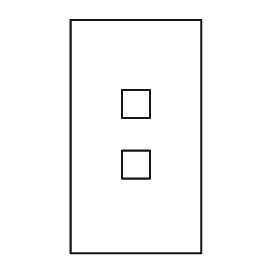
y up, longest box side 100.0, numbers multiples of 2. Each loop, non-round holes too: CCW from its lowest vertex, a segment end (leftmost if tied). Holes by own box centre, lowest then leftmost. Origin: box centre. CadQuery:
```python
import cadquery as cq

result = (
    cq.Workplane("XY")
    .moveTo(-28.0, -50.0)
    .lineTo(28.0, -50.0)
    .lineTo(28.0, 50.0)
    .lineTo(-28.0, 50.0)
    .close()
    .moveTo(-6.0, -18.0)
    .lineTo(6.0, -18.0)
    .lineTo(6.0, -6.0)
    .lineTo(-6.0, -6.0)
    .close()
    .moveTo(-6.0, 8.0)
    .lineTo(6.0, 8.0)
    .lineTo(6.0, 20.0)
    .lineTo(-6.0, 20.0)
    .close()
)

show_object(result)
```